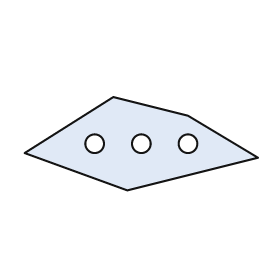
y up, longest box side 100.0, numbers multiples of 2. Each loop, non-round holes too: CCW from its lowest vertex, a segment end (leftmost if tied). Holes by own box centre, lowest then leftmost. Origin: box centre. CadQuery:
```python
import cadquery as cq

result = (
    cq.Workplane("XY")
    .moveTo(-6.0, -20.0)
    .lineTo(50.0, -6.0)
    .lineTo(20.0, 12.0)
    .lineTo(-12.0, 20.0)
    .lineTo(-50.0, -4.0)
    .close()
    .moveTo(-20.0, 0.0)
    .circle(4.0)
    .moveTo(0.0, 0.0)
    .circle(4.0)
    .moveTo(20.0, 0.0)
    .circle(4.0)
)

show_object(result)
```